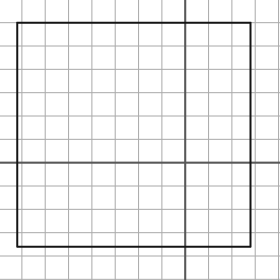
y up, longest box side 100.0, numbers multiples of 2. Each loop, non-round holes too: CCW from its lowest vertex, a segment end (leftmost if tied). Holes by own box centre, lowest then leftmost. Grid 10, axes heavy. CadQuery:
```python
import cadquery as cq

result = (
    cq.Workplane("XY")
    .moveTo(-72.0, -36.0)
    .lineTo(28.0, -36.0)
    .lineTo(28.0, 60.0)
    .lineTo(-72.0, 60.0)
    .close()
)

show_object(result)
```